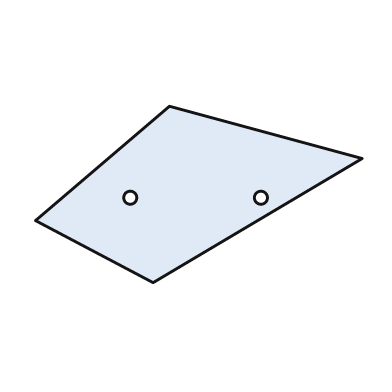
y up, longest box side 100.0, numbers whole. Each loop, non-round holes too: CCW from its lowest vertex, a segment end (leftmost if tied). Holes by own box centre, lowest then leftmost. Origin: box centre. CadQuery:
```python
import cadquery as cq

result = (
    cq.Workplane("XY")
    .moveTo(-14.0, -27.0)
    .lineTo(50.0, 11.0)
    .lineTo(-9.0, 27.0)
    .lineTo(-50.0, -8.0)
    .close()
    .moveTo(-21.0, -1.0)
    .circle(2.0)
    .moveTo(19.0, -1.0)
    .circle(2.0)
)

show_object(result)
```